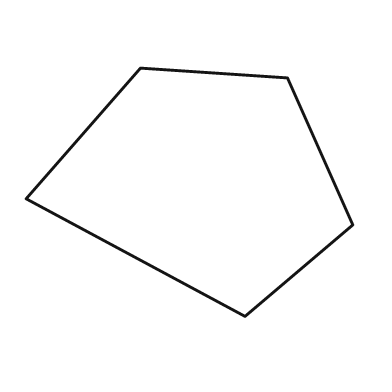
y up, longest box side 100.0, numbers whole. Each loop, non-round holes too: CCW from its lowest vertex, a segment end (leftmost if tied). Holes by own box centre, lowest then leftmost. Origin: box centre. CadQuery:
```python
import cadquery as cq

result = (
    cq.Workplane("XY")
    .moveTo(17.0, -38.0)
    .lineTo(50.0, -10.0)
    .lineTo(30.0, 35.0)
    .lineTo(-15.0, 38.0)
    .lineTo(-50.0, -2.0)
    .close()
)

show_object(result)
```